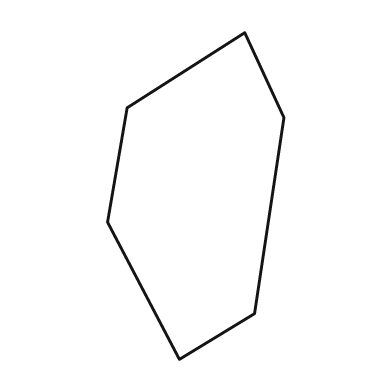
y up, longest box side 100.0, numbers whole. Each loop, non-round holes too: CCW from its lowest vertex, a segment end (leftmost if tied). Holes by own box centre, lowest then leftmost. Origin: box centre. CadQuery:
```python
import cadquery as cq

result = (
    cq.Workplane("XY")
    .moveTo(-5.0, -50.0)
    .lineTo(18.0, -36.0)
    .lineTo(27.0, 24.0)
    .lineTo(15.0, 50.0)
    .lineTo(-21.0, 27.0)
    .lineTo(-27.0, -8.0)
    .close()
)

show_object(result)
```